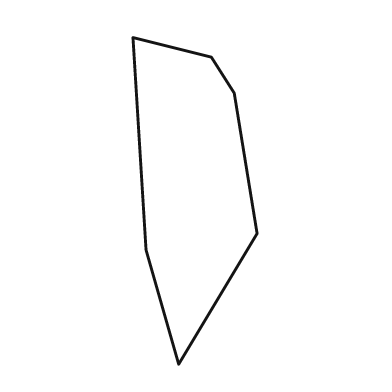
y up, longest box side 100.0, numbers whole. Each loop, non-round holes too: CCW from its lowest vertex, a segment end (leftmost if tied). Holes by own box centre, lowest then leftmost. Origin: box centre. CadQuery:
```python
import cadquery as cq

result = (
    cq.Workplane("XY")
    .moveTo(-5.0, -50.0)
    .lineTo(19.0, -10.0)
    .lineTo(12.0, 33.0)
    .lineTo(5.0, 44.0)
    .lineTo(-19.0, 50.0)
    .lineTo(-15.0, -15.0)
    .close()
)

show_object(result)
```